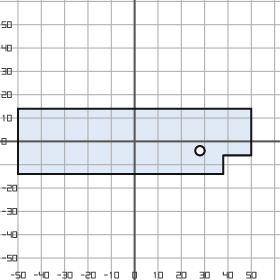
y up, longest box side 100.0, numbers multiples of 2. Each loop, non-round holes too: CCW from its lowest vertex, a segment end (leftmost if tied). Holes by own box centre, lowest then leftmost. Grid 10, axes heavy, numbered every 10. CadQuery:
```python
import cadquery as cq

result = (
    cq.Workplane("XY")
    .moveTo(-50.0, -14.0)
    .lineTo(38.0, -14.0)
    .lineTo(38.0, -6.0)
    .lineTo(50.0, -6.0)
    .lineTo(50.0, 14.0)
    .lineTo(-50.0, 14.0)
    .close()
    .moveTo(28.0, -4.0)
    .circle(2.0)
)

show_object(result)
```